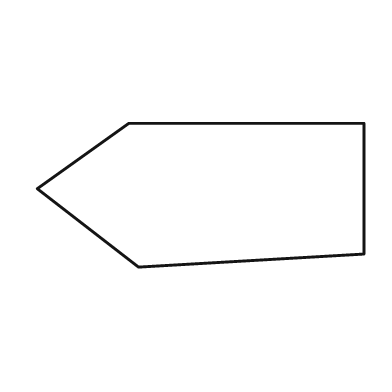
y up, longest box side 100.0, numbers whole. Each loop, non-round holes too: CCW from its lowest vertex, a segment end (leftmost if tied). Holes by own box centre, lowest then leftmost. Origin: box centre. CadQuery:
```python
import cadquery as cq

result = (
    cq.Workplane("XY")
    .moveTo(-19.0, -22.0)
    .lineTo(50.0, -18.0)
    .lineTo(50.0, 22.0)
    .lineTo(-22.0, 22.0)
    .lineTo(-50.0, 2.0)
    .close()
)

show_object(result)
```